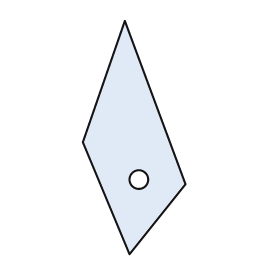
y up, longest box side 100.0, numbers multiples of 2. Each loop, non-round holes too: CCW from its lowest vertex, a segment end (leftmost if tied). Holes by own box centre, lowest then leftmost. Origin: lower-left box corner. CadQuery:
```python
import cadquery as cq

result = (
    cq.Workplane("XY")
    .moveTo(20.0, 0.0)
    .lineTo(44.0, 30.0)
    .lineTo(18.0, 100.0)
    .lineTo(0.0, 48.0)
    .close()
    .moveTo(24.0, 32.0)
    .circle(4.0)
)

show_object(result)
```